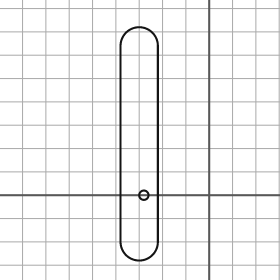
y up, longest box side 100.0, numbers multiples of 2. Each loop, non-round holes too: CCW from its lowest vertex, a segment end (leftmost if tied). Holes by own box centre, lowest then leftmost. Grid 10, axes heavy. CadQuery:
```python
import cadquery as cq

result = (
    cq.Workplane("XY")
    .moveTo(-38.0, -20.0)
    .threePointArc((-30.0, -28.0), (-22.0, -20.0))
    .lineTo(-22.0, 64.0)
    .threePointArc((-30.0, 72.0), (-38.0, 64.0))
    .close()
    .moveTo(-28.0, 0.0)
    .circle(2.0)
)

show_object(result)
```